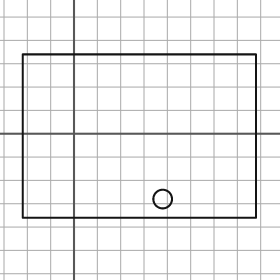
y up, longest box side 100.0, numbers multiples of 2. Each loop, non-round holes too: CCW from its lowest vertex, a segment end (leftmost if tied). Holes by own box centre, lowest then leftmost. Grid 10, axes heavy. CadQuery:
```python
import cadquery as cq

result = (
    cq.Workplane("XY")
    .moveTo(-22.0, -36.0)
    .lineTo(78.0, -36.0)
    .lineTo(78.0, 34.0)
    .lineTo(-22.0, 34.0)
    .close()
    .moveTo(38.0, -28.0)
    .circle(4.0)
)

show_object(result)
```